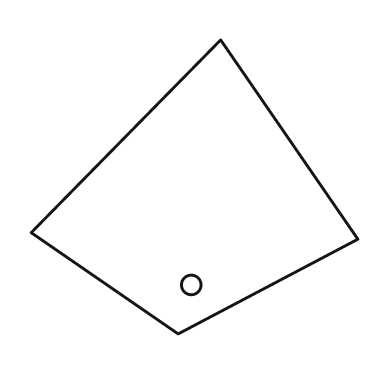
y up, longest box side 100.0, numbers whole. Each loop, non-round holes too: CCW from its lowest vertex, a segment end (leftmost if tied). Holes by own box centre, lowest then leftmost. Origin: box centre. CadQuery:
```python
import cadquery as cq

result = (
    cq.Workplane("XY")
    .moveTo(-5.0, -45.0)
    .lineTo(50.0, -16.0)
    .lineTo(8.0, 45.0)
    .lineTo(-50.0, -14.0)
    .close()
    .moveTo(-1.0, -30.0)
    .circle(3.0)
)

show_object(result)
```